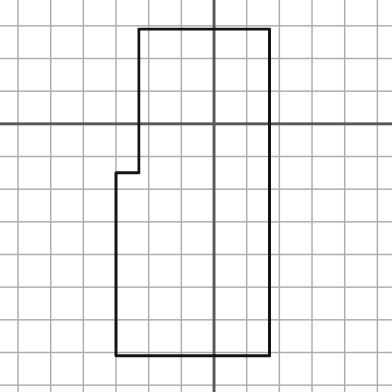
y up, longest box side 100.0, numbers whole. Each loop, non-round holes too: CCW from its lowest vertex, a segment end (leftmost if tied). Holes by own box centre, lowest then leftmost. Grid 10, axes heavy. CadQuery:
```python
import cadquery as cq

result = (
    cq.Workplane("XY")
    .moveTo(-30.0, -71.0)
    .lineTo(17.0, -71.0)
    .lineTo(17.0, 29.0)
    .lineTo(-23.0, 29.0)
    .lineTo(-23.0, -15.0)
    .lineTo(-30.0, -15.0)
    .close()
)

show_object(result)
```